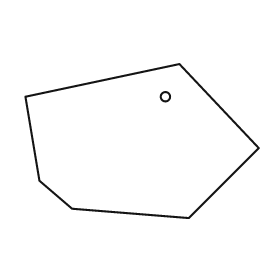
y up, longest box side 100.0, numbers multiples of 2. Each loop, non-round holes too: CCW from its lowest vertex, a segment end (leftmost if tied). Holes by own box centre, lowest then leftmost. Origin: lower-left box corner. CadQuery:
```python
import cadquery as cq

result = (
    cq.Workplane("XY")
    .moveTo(70.0, 0.0)
    .lineTo(100.0, 30.0)
    .lineTo(66.0, 66.0)
    .lineTo(0.0, 52.0)
    .lineTo(6.0, 16.0)
    .lineTo(20.0, 4.0)
    .close()
    .moveTo(60.0, 52.0)
    .circle(2.0)
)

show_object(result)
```